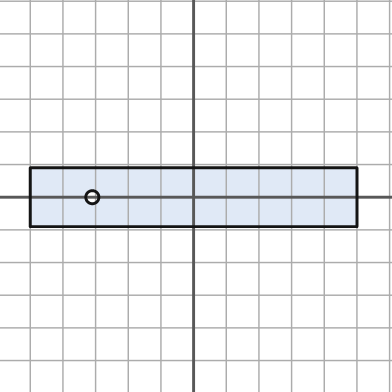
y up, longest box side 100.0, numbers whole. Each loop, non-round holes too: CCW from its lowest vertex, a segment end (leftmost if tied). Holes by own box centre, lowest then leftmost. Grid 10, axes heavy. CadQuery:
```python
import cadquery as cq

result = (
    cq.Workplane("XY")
    .moveTo(-50.0, -9.0)
    .lineTo(50.0, -9.0)
    .lineTo(50.0, 9.0)
    .lineTo(-50.0, 9.0)
    .close()
    .moveTo(-31.0, 0.0)
    .circle(2.0)
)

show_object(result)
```